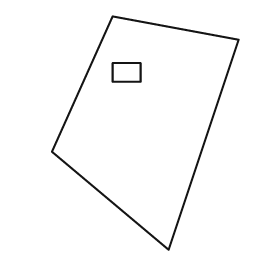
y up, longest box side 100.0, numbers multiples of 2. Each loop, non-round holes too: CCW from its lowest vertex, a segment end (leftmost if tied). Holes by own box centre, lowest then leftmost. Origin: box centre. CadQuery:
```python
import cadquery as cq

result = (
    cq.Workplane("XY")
    .moveTo(10.0, -50.0)
    .lineTo(40.0, 40.0)
    .lineTo(-14.0, 50.0)
    .lineTo(-40.0, -8.0)
    .close()
    .moveTo(-14.0, 22.0)
    .lineTo(-2.0, 22.0)
    .lineTo(-2.0, 30.0)
    .lineTo(-14.0, 30.0)
    .close()
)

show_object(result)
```